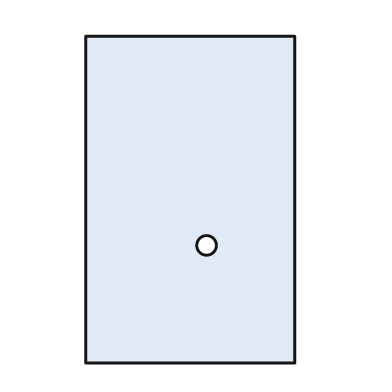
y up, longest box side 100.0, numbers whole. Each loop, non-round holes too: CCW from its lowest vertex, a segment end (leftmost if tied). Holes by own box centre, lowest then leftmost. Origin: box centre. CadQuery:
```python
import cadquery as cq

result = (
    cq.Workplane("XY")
    .moveTo(-32.0, -50.0)
    .lineTo(32.0, -50.0)
    .lineTo(32.0, 50.0)
    .lineTo(-32.0, 50.0)
    .close()
    .moveTo(5.0, -14.0)
    .circle(3.0)
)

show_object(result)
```